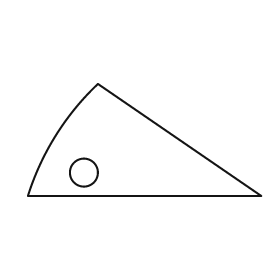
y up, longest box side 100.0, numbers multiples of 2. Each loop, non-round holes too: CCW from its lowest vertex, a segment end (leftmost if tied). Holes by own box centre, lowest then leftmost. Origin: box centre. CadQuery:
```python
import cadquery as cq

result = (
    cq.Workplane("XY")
    .moveTo(-50.0, -24.0)
    .lineTo(50.0, -24.0)
    .lineTo(-20.0, 24.0)
    .threePointArc((-38.0, 2.0), (-50.0, -24.0))
    .close()
    .moveTo(-26.0, -14.0)
    .circle(6.0)
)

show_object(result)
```